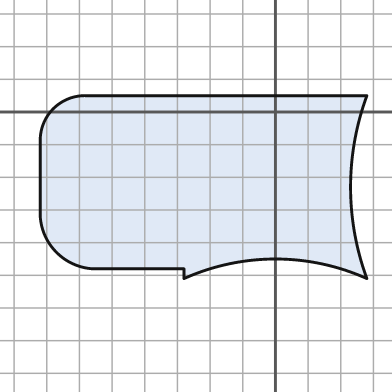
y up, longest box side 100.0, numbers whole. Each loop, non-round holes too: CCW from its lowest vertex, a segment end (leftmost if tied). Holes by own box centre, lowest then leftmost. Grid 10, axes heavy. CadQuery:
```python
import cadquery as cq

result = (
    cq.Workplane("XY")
    .moveTo(-28.0, -51.0)
    .threePointArc((0.0, -45.0), (28.0, -51.0))
    .threePointArc((23.0, -23.0), (28.0, 5.0))
    .lineTo(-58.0, 5.0)
    .threePointArc((-68.0, 1.0), (-72.0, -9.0))
    .lineTo(-72.0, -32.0)
    .threePointArc((-67.0, -43.0), (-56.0, -48.0))
    .lineTo(-28.0, -48.0)
    .close()
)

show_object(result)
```